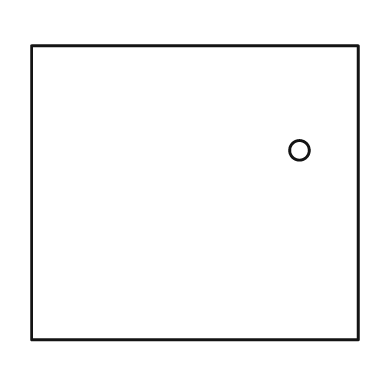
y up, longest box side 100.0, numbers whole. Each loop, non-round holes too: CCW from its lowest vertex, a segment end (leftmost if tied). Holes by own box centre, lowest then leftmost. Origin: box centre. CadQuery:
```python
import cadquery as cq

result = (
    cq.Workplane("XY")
    .moveTo(-50.0, -45.0)
    .lineTo(50.0, -45.0)
    .lineTo(50.0, 45.0)
    .lineTo(-50.0, 45.0)
    .close()
    .moveTo(32.0, 13.0)
    .circle(3.0)
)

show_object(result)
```